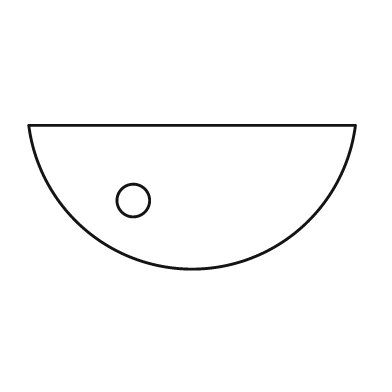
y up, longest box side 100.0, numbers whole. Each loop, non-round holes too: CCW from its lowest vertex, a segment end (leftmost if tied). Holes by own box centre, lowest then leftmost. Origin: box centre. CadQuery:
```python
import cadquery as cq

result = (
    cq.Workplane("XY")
    .moveTo(-50.0, 22.0)
    .threePointArc((0.0, -22.0), (50.0, 22.0))
    .close()
    .moveTo(-18.0, -1.0)
    .circle(5.0)
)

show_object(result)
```